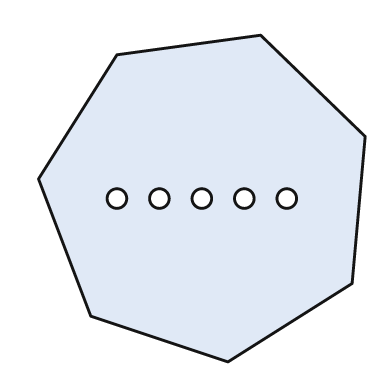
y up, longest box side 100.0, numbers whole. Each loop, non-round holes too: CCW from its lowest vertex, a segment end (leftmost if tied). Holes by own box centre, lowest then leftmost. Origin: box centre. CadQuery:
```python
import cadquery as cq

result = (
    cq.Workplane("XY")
    .moveTo(8.0, -50.0)
    .lineTo(46.0, -26.0)
    .lineTo(50.0, 19.0)
    .lineTo(18.0, 50.0)
    .lineTo(-26.0, 44.0)
    .lineTo(-50.0, 6.0)
    .lineTo(-34.0, -36.0)
    .close()
    .moveTo(-26.0, 0.0)
    .circle(3.0)
    .moveTo(-13.0, 0.0)
    .circle(3.0)
    .moveTo(0.0, 0.0)
    .circle(3.0)
    .moveTo(13.0, 0.0)
    .circle(3.0)
    .moveTo(26.0, 0.0)
    .circle(3.0)
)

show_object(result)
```